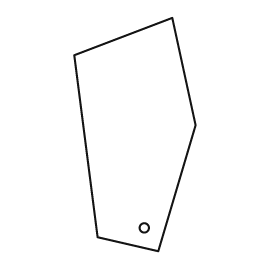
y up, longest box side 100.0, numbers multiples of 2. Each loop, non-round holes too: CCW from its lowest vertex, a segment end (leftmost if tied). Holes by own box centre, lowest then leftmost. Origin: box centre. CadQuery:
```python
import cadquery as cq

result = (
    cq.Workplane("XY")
    .moveTo(10.0, -50.0)
    .lineTo(26.0, 4.0)
    .lineTo(16.0, 50.0)
    .lineTo(-26.0, 34.0)
    .lineTo(-16.0, -44.0)
    .close()
    .moveTo(4.0, -40.0)
    .circle(2.0)
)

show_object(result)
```